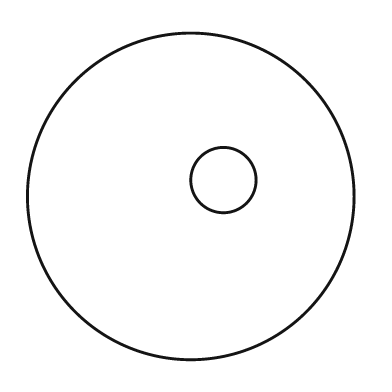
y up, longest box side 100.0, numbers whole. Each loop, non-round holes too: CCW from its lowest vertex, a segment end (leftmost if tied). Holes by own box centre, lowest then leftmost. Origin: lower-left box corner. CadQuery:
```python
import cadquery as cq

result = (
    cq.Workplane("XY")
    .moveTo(50.0, 50.0)
    .circle(50.0)
    .moveTo(60.0, 55.0)
    .circle(10.0)
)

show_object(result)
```